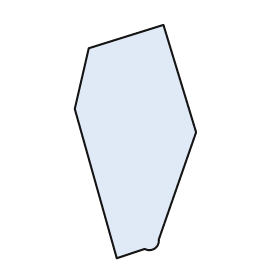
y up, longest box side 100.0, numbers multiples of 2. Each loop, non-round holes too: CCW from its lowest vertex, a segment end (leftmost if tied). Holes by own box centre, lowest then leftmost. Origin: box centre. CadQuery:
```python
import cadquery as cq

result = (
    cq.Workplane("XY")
    .moveTo(-8.0, -50.0)
    .lineTo(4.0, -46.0)
    .threePointArc((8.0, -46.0), (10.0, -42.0))
    .lineTo(26.0, 4.0)
    .lineTo(12.0, 50.0)
    .lineTo(-20.0, 40.0)
    .lineTo(-26.0, 14.0)
    .close()
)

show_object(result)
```